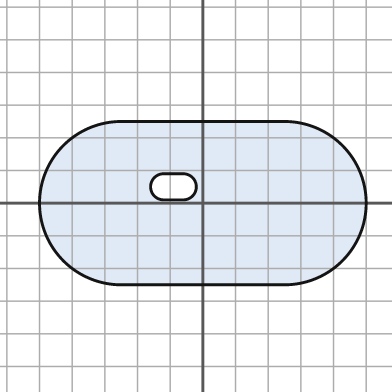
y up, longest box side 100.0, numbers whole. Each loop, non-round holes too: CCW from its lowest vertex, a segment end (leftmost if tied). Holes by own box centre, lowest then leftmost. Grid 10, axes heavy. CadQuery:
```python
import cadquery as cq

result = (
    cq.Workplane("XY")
    .moveTo(-25.0, -25.0)
    .lineTo(25.0, -25.0)
    .threePointArc((50.0, 0.0), (25.0, 25.0))
    .lineTo(-25.0, 25.0)
    .threePointArc((-50.0, 0.0), (-25.0, -25.0))
    .close()
    .moveTo(-12.0, 1.0)
    .lineTo(-6.0, 1.0)
    .threePointArc((-2.0, 5.0), (-6.0, 9.0))
    .lineTo(-12.0, 9.0)
    .threePointArc((-16.0, 5.0), (-12.0, 1.0))
    .close()
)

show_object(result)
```